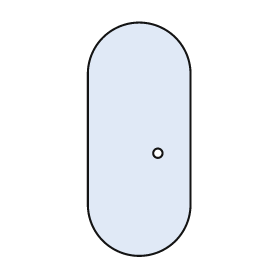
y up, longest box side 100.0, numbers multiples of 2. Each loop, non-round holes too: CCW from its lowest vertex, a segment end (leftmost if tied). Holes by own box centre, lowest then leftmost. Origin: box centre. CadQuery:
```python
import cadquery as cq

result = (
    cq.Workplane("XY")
    .moveTo(-22.0, -28.0)
    .threePointArc((0.0, -50.0), (22.0, -28.0))
    .lineTo(22.0, 28.0)
    .threePointArc((0.0, 50.0), (-22.0, 28.0))
    .close()
    .moveTo(8.0, -6.0)
    .circle(2.0)
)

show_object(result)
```